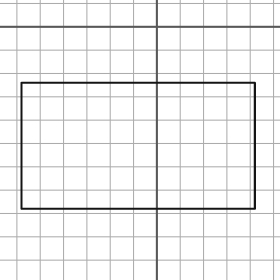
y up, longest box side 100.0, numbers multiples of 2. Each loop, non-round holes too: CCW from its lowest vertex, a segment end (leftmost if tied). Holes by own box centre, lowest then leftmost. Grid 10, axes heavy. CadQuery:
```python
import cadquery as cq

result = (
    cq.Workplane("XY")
    .moveTo(-58.0, -78.0)
    .lineTo(42.0, -78.0)
    .lineTo(42.0, -24.0)
    .lineTo(-58.0, -24.0)
    .close()
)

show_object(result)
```